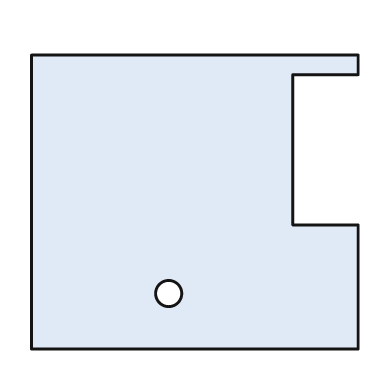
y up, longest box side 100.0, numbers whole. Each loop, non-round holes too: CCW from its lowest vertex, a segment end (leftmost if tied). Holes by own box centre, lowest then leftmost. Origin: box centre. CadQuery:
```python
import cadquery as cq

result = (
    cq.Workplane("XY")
    .moveTo(-50.0, -45.0)
    .lineTo(50.0, -45.0)
    .lineTo(50.0, -7.0)
    .lineTo(30.0, -7.0)
    .lineTo(30.0, 39.0)
    .lineTo(50.0, 39.0)
    .lineTo(50.0, 45.0)
    .lineTo(-50.0, 45.0)
    .close()
    .moveTo(-8.0, -28.0)
    .circle(4.0)
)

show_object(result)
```